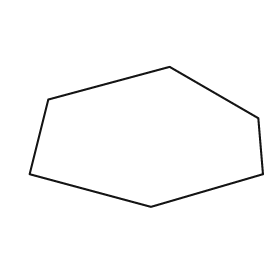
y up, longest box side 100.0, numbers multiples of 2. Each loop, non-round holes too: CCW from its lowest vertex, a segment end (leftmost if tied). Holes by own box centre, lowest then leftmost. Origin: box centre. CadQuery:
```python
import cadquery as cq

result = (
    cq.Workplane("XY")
    .moveTo(2.0, -30.0)
    .lineTo(50.0, -16.0)
    .lineTo(48.0, 8.0)
    .lineTo(10.0, 30.0)
    .lineTo(-42.0, 16.0)
    .lineTo(-50.0, -16.0)
    .close()
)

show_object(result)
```